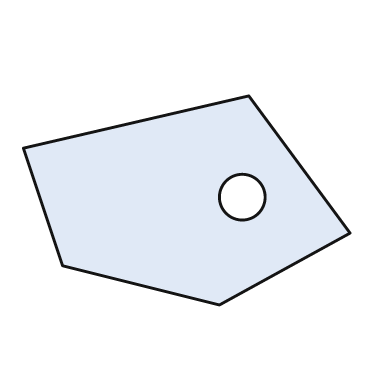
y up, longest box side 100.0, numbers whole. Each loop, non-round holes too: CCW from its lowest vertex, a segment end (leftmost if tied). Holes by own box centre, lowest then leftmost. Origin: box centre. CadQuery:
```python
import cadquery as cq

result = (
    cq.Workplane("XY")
    .moveTo(10.0, -32.0)
    .lineTo(50.0, -10.0)
    .lineTo(19.0, 32.0)
    .lineTo(-50.0, 16.0)
    .lineTo(-38.0, -20.0)
    .close()
    .moveTo(17.0, 1.0)
    .circle(7.0)
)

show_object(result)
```